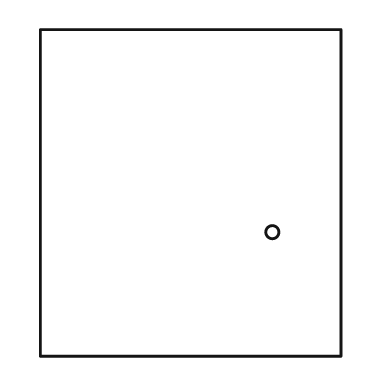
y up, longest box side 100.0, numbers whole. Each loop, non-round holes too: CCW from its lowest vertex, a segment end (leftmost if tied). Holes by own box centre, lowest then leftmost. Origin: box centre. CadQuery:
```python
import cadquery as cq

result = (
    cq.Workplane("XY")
    .moveTo(-46.0, -50.0)
    .lineTo(46.0, -50.0)
    .lineTo(46.0, 50.0)
    .lineTo(-46.0, 50.0)
    .close()
    .moveTo(25.0, -12.0)
    .circle(2.0)
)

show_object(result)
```